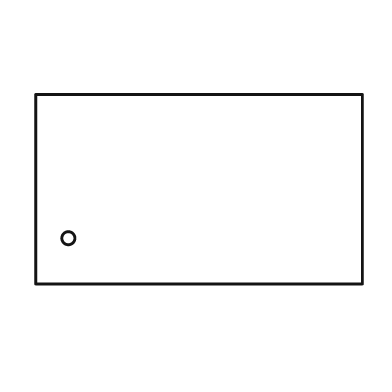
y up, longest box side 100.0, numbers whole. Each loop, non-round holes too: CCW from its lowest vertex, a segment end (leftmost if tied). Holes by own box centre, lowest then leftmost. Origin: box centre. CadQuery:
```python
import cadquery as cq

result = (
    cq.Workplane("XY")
    .moveTo(-50.0, -29.0)
    .lineTo(50.0, -29.0)
    .lineTo(50.0, 29.0)
    .lineTo(-50.0, 29.0)
    .close()
    .moveTo(-40.0, -15.0)
    .circle(2.0)
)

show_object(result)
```